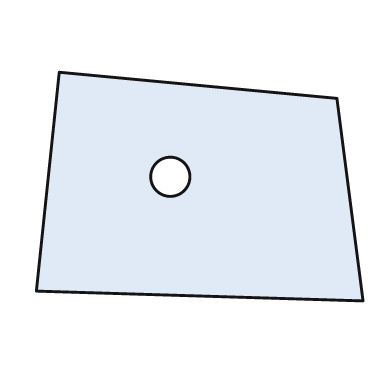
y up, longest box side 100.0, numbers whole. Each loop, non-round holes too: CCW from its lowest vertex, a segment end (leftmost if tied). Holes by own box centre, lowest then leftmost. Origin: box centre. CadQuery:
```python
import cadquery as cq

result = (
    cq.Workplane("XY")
    .moveTo(50.0, -35.0)
    .lineTo(42.0, 27.0)
    .lineTo(-43.0, 35.0)
    .lineTo(-50.0, -32.0)
    .close()
    .moveTo(-9.0, 3.0)
    .circle(6.0)
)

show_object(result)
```